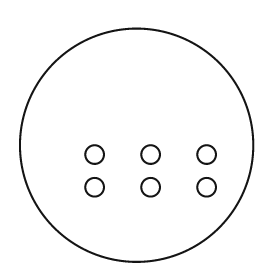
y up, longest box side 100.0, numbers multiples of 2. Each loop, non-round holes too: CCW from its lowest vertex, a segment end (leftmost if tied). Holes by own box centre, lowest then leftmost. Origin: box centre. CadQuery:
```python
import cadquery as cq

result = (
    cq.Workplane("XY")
    .moveTo(0.0, 0.0)
    .circle(50.0)
    .moveTo(-18.0, -18.0)
    .circle(4.0)
    .moveTo(6.0, -18.0)
    .circle(4.0)
    .moveTo(30.0, -18.0)
    .circle(4.0)
    .moveTo(-18.0, -4.0)
    .circle(4.0)
    .moveTo(6.0, -4.0)
    .circle(4.0)
    .moveTo(30.0, -4.0)
    .circle(4.0)
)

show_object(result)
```